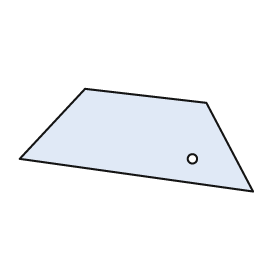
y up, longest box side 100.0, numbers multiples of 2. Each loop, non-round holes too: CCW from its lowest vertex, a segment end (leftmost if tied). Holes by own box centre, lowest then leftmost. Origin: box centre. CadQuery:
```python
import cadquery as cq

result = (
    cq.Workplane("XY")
    .moveTo(50.0, -22.0)
    .lineTo(30.0, 16.0)
    .lineTo(-22.0, 22.0)
    .lineTo(-50.0, -8.0)
    .close()
    .moveTo(24.0, -8.0)
    .circle(2.0)
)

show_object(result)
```